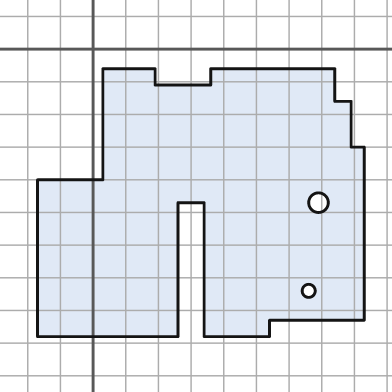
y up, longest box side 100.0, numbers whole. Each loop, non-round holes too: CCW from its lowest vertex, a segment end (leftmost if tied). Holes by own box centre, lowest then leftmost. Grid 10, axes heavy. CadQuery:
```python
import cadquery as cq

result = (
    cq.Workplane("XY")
    .moveTo(-17.0, -88.0)
    .lineTo(26.0, -88.0)
    .lineTo(26.0, -47.0)
    .lineTo(34.0, -47.0)
    .lineTo(34.0, -88.0)
    .lineTo(54.0, -88.0)
    .lineTo(54.0, -83.0)
    .lineTo(83.0, -83.0)
    .lineTo(83.0, -30.0)
    .lineTo(79.0, -30.0)
    .lineTo(79.0, -16.0)
    .lineTo(74.0, -16.0)
    .lineTo(74.0, -6.0)
    .lineTo(36.0, -6.0)
    .lineTo(36.0, -11.0)
    .lineTo(19.0, -11.0)
    .lineTo(19.0, -6.0)
    .lineTo(3.0, -6.0)
    .lineTo(3.0, -40.0)
    .lineTo(-17.0, -40.0)
    .close()
    .moveTo(66.0, -74.0)
    .circle(2.0)
    .moveTo(69.0, -47.0)
    .circle(3.0)
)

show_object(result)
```